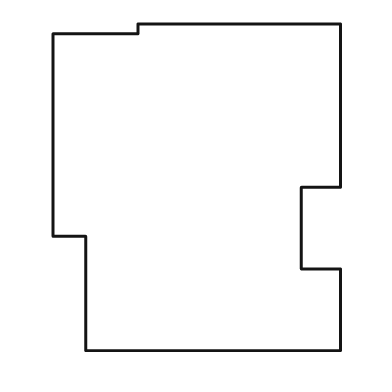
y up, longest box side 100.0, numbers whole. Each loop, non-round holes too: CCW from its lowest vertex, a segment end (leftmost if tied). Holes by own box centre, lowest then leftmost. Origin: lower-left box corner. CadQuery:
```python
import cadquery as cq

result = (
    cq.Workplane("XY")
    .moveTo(10.0, 0.0)
    .lineTo(88.0, 0.0)
    .lineTo(88.0, 25.0)
    .lineTo(76.0, 25.0)
    .lineTo(76.0, 50.0)
    .lineTo(88.0, 50.0)
    .lineTo(88.0, 100.0)
    .lineTo(26.0, 100.0)
    .lineTo(26.0, 97.0)
    .lineTo(0.0, 97.0)
    .lineTo(0.0, 35.0)
    .lineTo(10.0, 35.0)
    .close()
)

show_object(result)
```